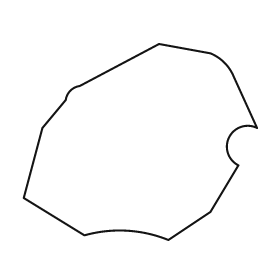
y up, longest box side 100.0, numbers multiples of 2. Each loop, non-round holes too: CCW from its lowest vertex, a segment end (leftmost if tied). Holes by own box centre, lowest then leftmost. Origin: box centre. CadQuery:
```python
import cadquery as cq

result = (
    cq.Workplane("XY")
    .moveTo(12.0, -42.0)
    .lineTo(30.0, -30.0)
    .lineTo(42.0, -10.0)
    .threePointArc((38.0, 2.0), (50.0, 6.0))
    .lineTo(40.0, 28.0)
    .threePointArc((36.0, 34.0), (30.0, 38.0))
    .lineTo(8.0, 42.0)
    .lineTo(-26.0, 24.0)
    .threePointArc((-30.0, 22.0), (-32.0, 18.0))
    .lineTo(-42.0, 6.0)
    .lineTo(-50.0, -24.0)
    .lineTo(-24.0, -40.0)
    .threePointArc((-6.0, -38.0), (12.0, -42.0))
    .close()
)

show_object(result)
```